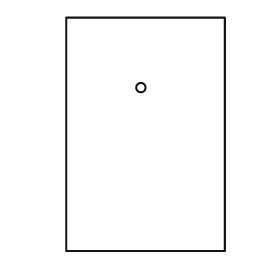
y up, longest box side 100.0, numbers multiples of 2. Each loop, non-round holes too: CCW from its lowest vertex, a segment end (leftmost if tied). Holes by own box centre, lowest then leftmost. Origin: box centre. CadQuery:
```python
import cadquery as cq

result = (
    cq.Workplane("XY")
    .moveTo(-34.0, -50.0)
    .lineTo(34.0, -50.0)
    .lineTo(34.0, 50.0)
    .lineTo(-34.0, 50.0)
    .close()
    .moveTo(-2.0, 20.0)
    .circle(2.0)
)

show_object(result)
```